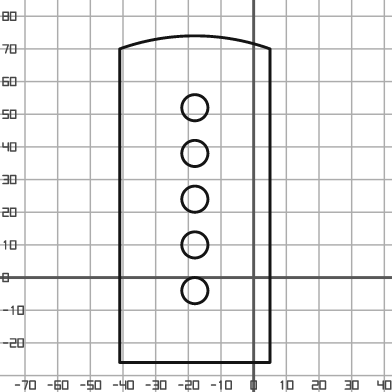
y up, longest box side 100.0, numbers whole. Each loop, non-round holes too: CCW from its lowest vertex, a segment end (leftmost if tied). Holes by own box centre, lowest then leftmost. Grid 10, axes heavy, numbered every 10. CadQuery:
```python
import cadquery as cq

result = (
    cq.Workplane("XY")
    .moveTo(-41.0, -26.0)
    .lineTo(5.0, -26.0)
    .lineTo(5.0, 70.0)
    .threePointArc((-18.0, 74.0), (-41.0, 70.0))
    .close()
    .moveTo(-18.0, -4.0)
    .circle(4.0)
    .moveTo(-18.0, 10.0)
    .circle(4.0)
    .moveTo(-18.0, 24.0)
    .circle(4.0)
    .moveTo(-18.0, 38.0)
    .circle(4.0)
    .moveTo(-18.0, 52.0)
    .circle(4.0)
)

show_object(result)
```